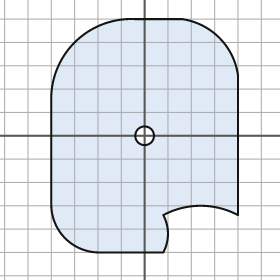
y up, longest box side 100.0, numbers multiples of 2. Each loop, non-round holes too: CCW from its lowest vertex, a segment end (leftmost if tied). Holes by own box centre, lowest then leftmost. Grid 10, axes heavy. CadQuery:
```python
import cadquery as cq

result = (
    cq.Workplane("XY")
    .moveTo(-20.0, -50.0)
    .lineTo(8.0, -50.0)
    .threePointArc((10.0, -42.0), (8.0, -34.0))
    .threePointArc((24.0, -30.0), (40.0, -34.0))
    .lineTo(40.0, 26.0)
    .threePointArc((32.0, 42.0), (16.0, 50.0))
    .lineTo(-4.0, 50.0)
    .threePointArc((-30.0, 40.0), (-40.0, 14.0))
    .lineTo(-40.0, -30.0)
    .threePointArc((-34.0, -44.0), (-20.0, -50.0))
    .close()
    .moveTo(0.0, 0.0)
    .circle(4.0)
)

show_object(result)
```